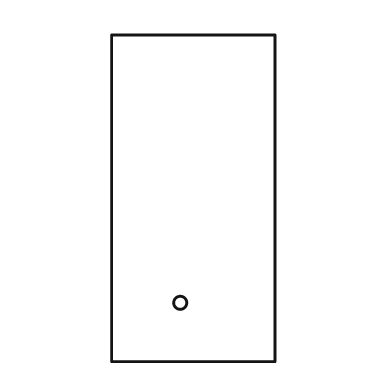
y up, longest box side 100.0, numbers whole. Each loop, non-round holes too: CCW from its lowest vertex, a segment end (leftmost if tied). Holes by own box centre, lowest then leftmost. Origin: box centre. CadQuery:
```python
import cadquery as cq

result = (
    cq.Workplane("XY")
    .moveTo(-25.0, -50.0)
    .lineTo(25.0, -50.0)
    .lineTo(25.0, 50.0)
    .lineTo(-25.0, 50.0)
    .close()
    .moveTo(-4.0, -32.0)
    .circle(2.0)
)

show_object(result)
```